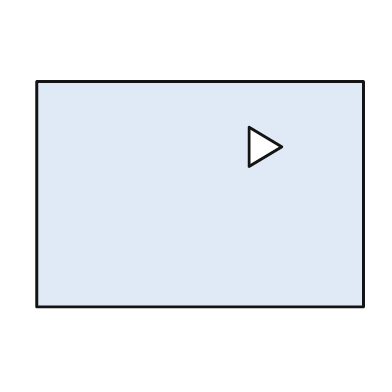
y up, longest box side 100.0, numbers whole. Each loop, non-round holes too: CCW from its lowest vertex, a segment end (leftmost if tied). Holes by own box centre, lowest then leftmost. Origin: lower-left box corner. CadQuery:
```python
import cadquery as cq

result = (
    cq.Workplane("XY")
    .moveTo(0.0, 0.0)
    .lineTo(100.0, 0.0)
    .lineTo(100.0, 69.0)
    .lineTo(0.0, 69.0)
    .close()
    .moveTo(65.0, 43.0)
    .lineTo(75.0, 49.0)
    .lineTo(65.0, 55.0)
    .close()
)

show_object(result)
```